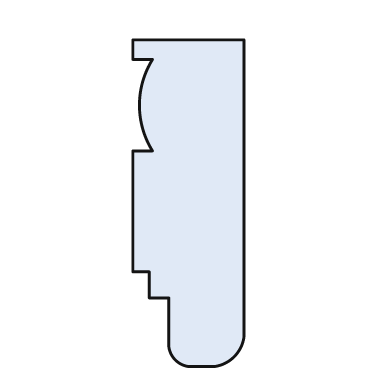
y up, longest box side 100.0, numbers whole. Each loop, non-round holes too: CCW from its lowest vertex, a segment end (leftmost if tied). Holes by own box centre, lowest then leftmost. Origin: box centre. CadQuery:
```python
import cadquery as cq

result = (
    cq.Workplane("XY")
    .moveTo(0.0, -50.0)
    .lineTo(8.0, -50.0)
    .threePointArc((14.0, -47.0), (17.0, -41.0))
    .lineTo(17.0, 50.0)
    .lineTo(-17.0, 50.0)
    .lineTo(-17.0, 44.0)
    .lineTo(-11.0, 44.0)
    .threePointArc((-15.0, 30.0), (-11.0, 16.0))
    .lineTo(-17.0, 16.0)
    .lineTo(-17.0, -21.0)
    .lineTo(-12.0, -21.0)
    .lineTo(-12.0, -29.0)
    .lineTo(-6.0, -29.0)
    .lineTo(-6.0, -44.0)
    .threePointArc((-4.0, -48.0), (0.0, -50.0))
    .close()
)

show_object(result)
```